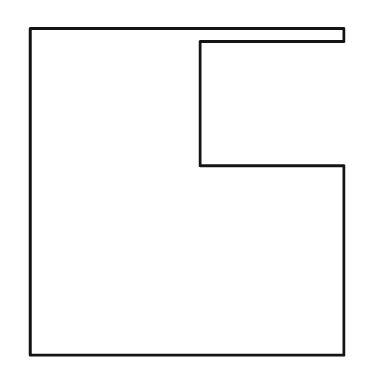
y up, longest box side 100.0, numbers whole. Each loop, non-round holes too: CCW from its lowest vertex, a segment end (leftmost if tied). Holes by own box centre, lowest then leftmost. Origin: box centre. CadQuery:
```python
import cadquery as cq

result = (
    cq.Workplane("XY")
    .moveTo(-48.0, -50.0)
    .lineTo(48.0, -50.0)
    .lineTo(48.0, 8.0)
    .lineTo(4.0, 8.0)
    .lineTo(4.0, 46.0)
    .lineTo(48.0, 46.0)
    .lineTo(48.0, 50.0)
    .lineTo(-48.0, 50.0)
    .close()
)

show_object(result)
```